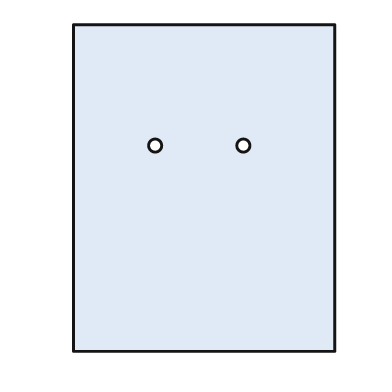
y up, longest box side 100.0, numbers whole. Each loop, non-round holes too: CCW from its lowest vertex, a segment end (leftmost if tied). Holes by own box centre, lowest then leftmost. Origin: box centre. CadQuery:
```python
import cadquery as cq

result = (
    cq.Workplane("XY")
    .moveTo(-40.0, -50.0)
    .lineTo(40.0, -50.0)
    .lineTo(40.0, 50.0)
    .lineTo(-40.0, 50.0)
    .close()
    .moveTo(-15.0, 13.0)
    .circle(2.0)
    .moveTo(12.0, 13.0)
    .circle(2.0)
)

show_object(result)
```